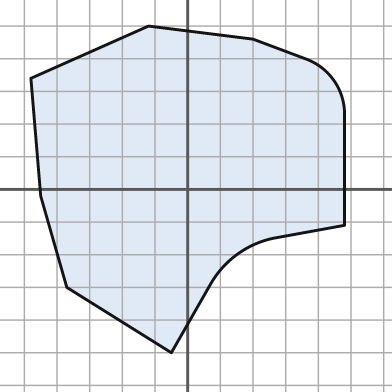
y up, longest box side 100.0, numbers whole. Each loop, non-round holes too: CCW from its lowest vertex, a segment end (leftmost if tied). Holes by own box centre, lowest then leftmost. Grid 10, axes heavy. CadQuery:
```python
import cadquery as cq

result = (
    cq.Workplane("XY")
    .moveTo(-5.0, -50.0)
    .lineTo(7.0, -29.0)
    .threePointArc((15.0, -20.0), (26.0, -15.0))
    .lineTo(48.0, -11.0)
    .lineTo(48.0, 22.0)
    .threePointArc((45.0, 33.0), (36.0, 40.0))
    .lineTo(20.0, 46.0)
    .lineTo(-12.0, 50.0)
    .lineTo(-48.0, 34.0)
    .lineTo(-45.0, -2.0)
    .lineTo(-37.0, -30.0)
    .close()
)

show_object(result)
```